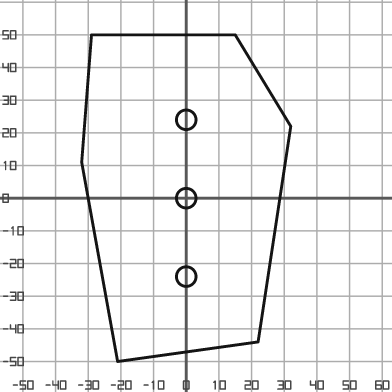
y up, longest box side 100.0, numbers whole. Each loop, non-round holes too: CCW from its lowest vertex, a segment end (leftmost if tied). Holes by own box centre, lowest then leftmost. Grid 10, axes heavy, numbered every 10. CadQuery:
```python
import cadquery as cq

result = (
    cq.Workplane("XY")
    .moveTo(-21.0, -50.0)
    .lineTo(22.0, -44.0)
    .lineTo(32.0, 22.0)
    .lineTo(15.0, 50.0)
    .lineTo(-29.0, 50.0)
    .lineTo(-32.0, 11.0)
    .close()
    .moveTo(0.0, -24.0)
    .circle(3.0)
    .moveTo(0.0, 0.0)
    .circle(3.0)
    .moveTo(0.0, 24.0)
    .circle(3.0)
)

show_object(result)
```